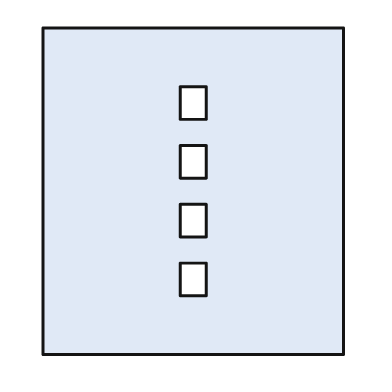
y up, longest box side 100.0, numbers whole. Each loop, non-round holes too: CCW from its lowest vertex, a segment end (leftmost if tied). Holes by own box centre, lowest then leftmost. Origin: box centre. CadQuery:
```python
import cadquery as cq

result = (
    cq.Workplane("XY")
    .moveTo(-46.0, -50.0)
    .lineTo(46.0, -50.0)
    .lineTo(46.0, 50.0)
    .lineTo(-46.0, 50.0)
    .close()
    .moveTo(-4.0, -32.0)
    .lineTo(4.0, -32.0)
    .lineTo(4.0, -22.0)
    .lineTo(-4.0, -22.0)
    .close()
    .moveTo(-4.0, -14.0)
    .lineTo(4.0, -14.0)
    .lineTo(4.0, -4.0)
    .lineTo(-4.0, -4.0)
    .close()
    .moveTo(-4.0, 4.0)
    .lineTo(4.0, 4.0)
    .lineTo(4.0, 14.0)
    .lineTo(-4.0, 14.0)
    .close()
    .moveTo(-4.0, 22.0)
    .lineTo(4.0, 22.0)
    .lineTo(4.0, 32.0)
    .lineTo(-4.0, 32.0)
    .close()
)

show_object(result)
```